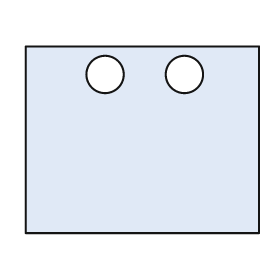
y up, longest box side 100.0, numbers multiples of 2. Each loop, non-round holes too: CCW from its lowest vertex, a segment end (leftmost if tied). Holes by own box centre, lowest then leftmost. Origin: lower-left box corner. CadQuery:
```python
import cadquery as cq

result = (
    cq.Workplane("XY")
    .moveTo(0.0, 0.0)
    .lineTo(100.0, 0.0)
    .lineTo(100.0, 80.0)
    .lineTo(0.0, 80.0)
    .close()
    .moveTo(34.0, 68.0)
    .circle(8.0)
    .moveTo(68.0, 68.0)
    .circle(8.0)
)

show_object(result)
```